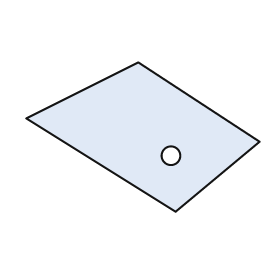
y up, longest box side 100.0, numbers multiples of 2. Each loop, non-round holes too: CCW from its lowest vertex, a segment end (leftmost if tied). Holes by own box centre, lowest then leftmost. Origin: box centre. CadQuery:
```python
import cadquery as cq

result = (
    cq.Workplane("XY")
    .moveTo(14.0, -32.0)
    .lineTo(50.0, -2.0)
    .lineTo(-2.0, 32.0)
    .lineTo(-50.0, 8.0)
    .close()
    .moveTo(12.0, -8.0)
    .circle(4.0)
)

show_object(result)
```